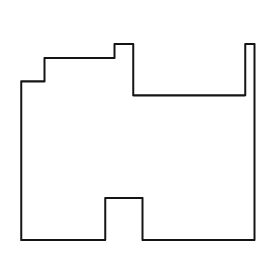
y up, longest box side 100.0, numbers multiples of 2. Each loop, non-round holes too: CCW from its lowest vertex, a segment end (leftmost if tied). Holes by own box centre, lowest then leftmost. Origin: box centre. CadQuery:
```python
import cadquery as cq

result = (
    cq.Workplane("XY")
    .moveTo(-50.0, -42.0)
    .lineTo(-14.0, -42.0)
    .lineTo(-14.0, -24.0)
    .lineTo(2.0, -24.0)
    .lineTo(2.0, -42.0)
    .lineTo(50.0, -42.0)
    .lineTo(50.0, 42.0)
    .lineTo(46.0, 42.0)
    .lineTo(46.0, 20.0)
    .lineTo(-2.0, 20.0)
    .lineTo(-2.0, 42.0)
    .lineTo(-10.0, 42.0)
    .lineTo(-10.0, 36.0)
    .lineTo(-40.0, 36.0)
    .lineTo(-40.0, 26.0)
    .lineTo(-50.0, 26.0)
    .close()
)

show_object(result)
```